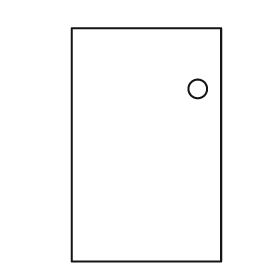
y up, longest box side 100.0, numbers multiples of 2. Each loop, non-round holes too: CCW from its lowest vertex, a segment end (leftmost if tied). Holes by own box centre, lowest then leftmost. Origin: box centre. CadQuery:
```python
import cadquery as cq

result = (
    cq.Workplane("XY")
    .moveTo(-32.0, -50.0)
    .lineTo(32.0, -50.0)
    .lineTo(32.0, 50.0)
    .lineTo(-32.0, 50.0)
    .close()
    .moveTo(22.0, 24.0)
    .circle(4.0)
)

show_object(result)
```